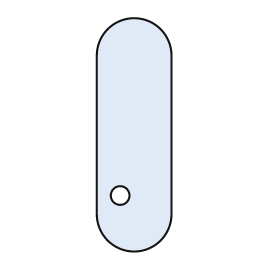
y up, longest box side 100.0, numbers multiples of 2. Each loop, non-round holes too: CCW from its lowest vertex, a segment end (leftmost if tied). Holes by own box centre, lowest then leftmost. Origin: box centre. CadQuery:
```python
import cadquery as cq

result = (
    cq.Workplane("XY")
    .moveTo(-16.0, -34.0)
    .threePointArc((0.0, -50.0), (16.0, -34.0))
    .lineTo(16.0, 34.0)
    .threePointArc((0.0, 50.0), (-16.0, 34.0))
    .close()
    .moveTo(-6.0, -26.0)
    .circle(4.0)
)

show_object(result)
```